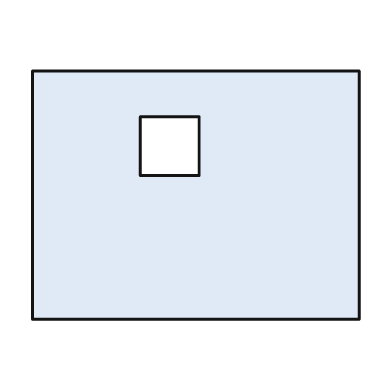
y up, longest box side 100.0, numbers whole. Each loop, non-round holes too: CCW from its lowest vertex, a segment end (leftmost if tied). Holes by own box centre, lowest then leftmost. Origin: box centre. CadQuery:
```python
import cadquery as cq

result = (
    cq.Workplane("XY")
    .moveTo(-50.0, -38.0)
    .lineTo(50.0, -38.0)
    .lineTo(50.0, 38.0)
    .lineTo(-50.0, 38.0)
    .close()
    .moveTo(-17.0, 6.0)
    .lineTo(1.0, 6.0)
    .lineTo(1.0, 24.0)
    .lineTo(-17.0, 24.0)
    .close()
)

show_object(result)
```